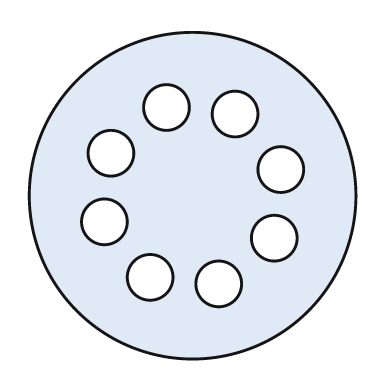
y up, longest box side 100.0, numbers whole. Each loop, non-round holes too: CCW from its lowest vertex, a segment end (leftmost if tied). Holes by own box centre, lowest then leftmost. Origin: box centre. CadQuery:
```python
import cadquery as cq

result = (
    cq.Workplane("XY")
    .moveTo(0.0, 0.0)
    .circle(50.0)
    .moveTo(8.0, -27.0)
    .circle(7.0)
    .moveTo(-13.0, -25.0)
    .circle(7.0)
    .moveTo(25.0, -13.0)
    .circle(7.0)
    .moveTo(-27.0, -8.0)
    .circle(7.0)
    .moveTo(27.0, 8.0)
    .circle(7.0)
    .moveTo(-25.0, 13.0)
    .circle(7.0)
    .moveTo(13.0, 25.0)
    .circle(7.0)
    .moveTo(-8.0, 27.0)
    .circle(7.0)
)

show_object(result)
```